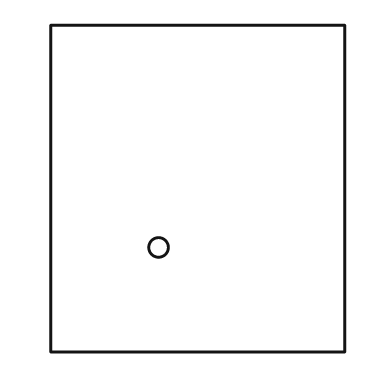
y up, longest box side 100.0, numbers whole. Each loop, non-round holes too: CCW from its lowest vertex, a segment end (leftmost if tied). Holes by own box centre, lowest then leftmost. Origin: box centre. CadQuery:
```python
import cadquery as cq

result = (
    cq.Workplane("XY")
    .moveTo(-45.0, -50.0)
    .lineTo(45.0, -50.0)
    .lineTo(45.0, 50.0)
    .lineTo(-45.0, 50.0)
    .close()
    .moveTo(-12.0, -18.0)
    .circle(3.0)
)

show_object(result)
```